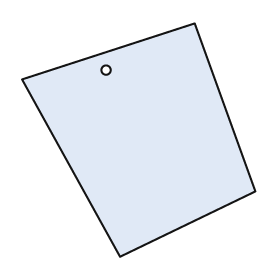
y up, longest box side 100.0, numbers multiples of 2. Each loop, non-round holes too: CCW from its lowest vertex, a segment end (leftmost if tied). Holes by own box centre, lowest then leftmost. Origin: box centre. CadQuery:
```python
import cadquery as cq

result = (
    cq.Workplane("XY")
    .moveTo(-8.0, -50.0)
    .lineTo(50.0, -22.0)
    .lineTo(24.0, 50.0)
    .lineTo(-50.0, 26.0)
    .close()
    .moveTo(-14.0, 30.0)
    .circle(2.0)
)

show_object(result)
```